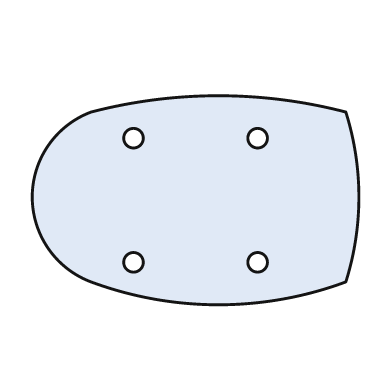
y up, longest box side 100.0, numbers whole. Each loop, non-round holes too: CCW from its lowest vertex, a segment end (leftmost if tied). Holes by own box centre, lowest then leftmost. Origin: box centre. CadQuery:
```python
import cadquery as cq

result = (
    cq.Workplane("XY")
    .moveTo(-32.0, -25.0)
    .threePointArc((7.0, -32.0), (46.0, -25.0))
    .threePointArc((50.0, 1.0), (46.0, 27.0))
    .threePointArc((7.0, 32.0), (-32.0, 27.0))
    .threePointArc((-50.0, 1.0), (-32.0, -25.0))
    .close()
    .moveTo(-19.0, -19.0)
    .circle(3.0)
    .moveTo(19.0, -19.0)
    .circle(3.0)
    .moveTo(-19.0, 19.0)
    .circle(3.0)
    .moveTo(19.0, 19.0)
    .circle(3.0)
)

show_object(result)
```